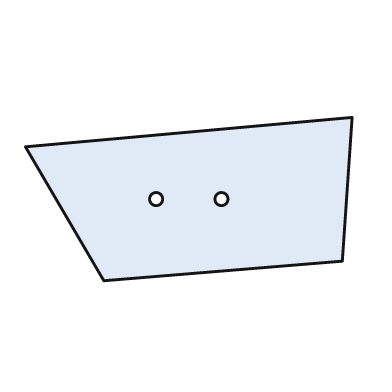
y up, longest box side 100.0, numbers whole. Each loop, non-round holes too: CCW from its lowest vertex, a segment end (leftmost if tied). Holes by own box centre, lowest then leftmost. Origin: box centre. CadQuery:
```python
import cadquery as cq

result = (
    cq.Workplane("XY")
    .moveTo(-26.0, -25.0)
    .lineTo(47.0, -19.0)
    .lineTo(50.0, 25.0)
    .lineTo(-50.0, 16.0)
    .close()
    .moveTo(-10.0, 0.0)
    .circle(2.0)
    .moveTo(10.0, 0.0)
    .circle(2.0)
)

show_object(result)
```